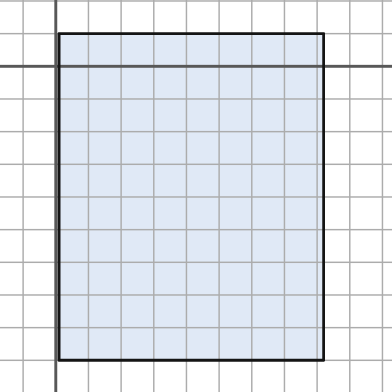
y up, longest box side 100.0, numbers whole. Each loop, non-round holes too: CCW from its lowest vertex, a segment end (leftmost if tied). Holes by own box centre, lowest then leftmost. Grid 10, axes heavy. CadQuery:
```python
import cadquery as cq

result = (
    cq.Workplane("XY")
    .moveTo(1.0, -90.0)
    .lineTo(82.0, -90.0)
    .lineTo(82.0, 10.0)
    .lineTo(1.0, 10.0)
    .close()
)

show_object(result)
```